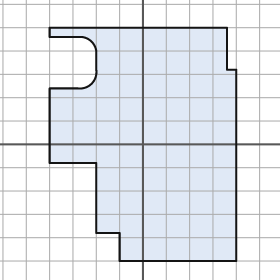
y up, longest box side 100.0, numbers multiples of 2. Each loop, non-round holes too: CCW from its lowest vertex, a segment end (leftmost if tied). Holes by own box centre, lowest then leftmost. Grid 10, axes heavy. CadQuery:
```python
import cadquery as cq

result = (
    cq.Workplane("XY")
    .moveTo(-10.0, -50.0)
    .lineTo(40.0, -50.0)
    .lineTo(40.0, 32.0)
    .lineTo(36.0, 32.0)
    .lineTo(36.0, 50.0)
    .lineTo(-40.0, 50.0)
    .lineTo(-40.0, 46.0)
    .lineTo(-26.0, 46.0)
    .threePointArc((-22.0, 44.0), (-20.0, 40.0))
    .lineTo(-20.0, 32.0)
    .threePointArc((-22.0, 26.0), (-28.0, 24.0))
    .lineTo(-40.0, 24.0)
    .lineTo(-40.0, -8.0)
    .lineTo(-20.0, -8.0)
    .lineTo(-20.0, -38.0)
    .lineTo(-10.0, -38.0)
    .close()
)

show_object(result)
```